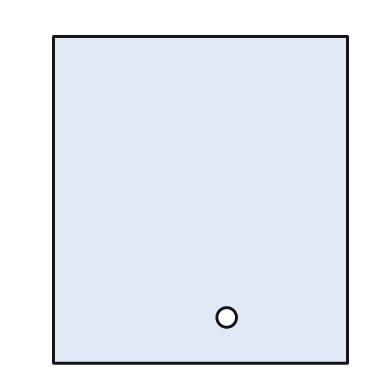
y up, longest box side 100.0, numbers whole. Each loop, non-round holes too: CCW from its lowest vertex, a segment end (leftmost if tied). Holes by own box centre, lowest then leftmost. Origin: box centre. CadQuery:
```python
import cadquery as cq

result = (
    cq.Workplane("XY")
    .moveTo(-45.0, -50.0)
    .lineTo(45.0, -50.0)
    .lineTo(45.0, 50.0)
    .lineTo(-45.0, 50.0)
    .close()
    .moveTo(8.0, -36.0)
    .circle(3.0)
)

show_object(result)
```